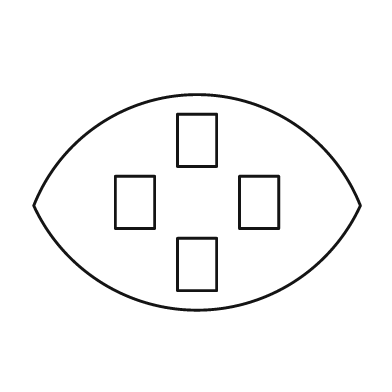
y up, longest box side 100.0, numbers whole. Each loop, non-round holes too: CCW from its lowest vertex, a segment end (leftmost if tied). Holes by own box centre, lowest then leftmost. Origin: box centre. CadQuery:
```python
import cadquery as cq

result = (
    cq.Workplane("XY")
    .moveTo(-50.0, -1.0)
    .threePointArc((0.0, -33.0), (50.0, -1.0))
    .threePointArc((0.0, 33.0), (-50.0, -1.0))
    .close()
    .moveTo(-6.0, -27.0)
    .lineTo(6.0, -27.0)
    .lineTo(6.0, -11.0)
    .lineTo(-6.0, -11.0)
    .close()
    .moveTo(-25.0, -8.0)
    .lineTo(-13.0, -8.0)
    .lineTo(-13.0, 8.0)
    .lineTo(-25.0, 8.0)
    .close()
    .moveTo(13.0, -8.0)
    .lineTo(25.0, -8.0)
    .lineTo(25.0, 8.0)
    .lineTo(13.0, 8.0)
    .close()
    .moveTo(-6.0, 11.0)
    .lineTo(6.0, 11.0)
    .lineTo(6.0, 27.0)
    .lineTo(-6.0, 27.0)
    .close()
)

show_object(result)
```